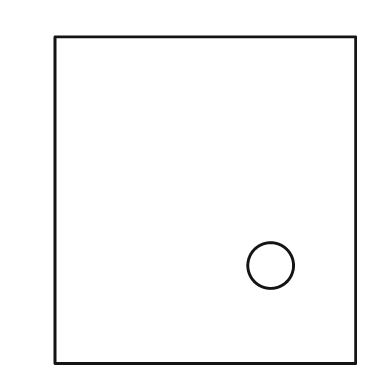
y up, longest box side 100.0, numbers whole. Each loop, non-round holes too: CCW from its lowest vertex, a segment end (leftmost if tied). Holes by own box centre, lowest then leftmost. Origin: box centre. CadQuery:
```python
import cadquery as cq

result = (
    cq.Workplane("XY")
    .moveTo(-46.0, -50.0)
    .lineTo(46.0, -50.0)
    .lineTo(46.0, 50.0)
    .lineTo(-46.0, 50.0)
    .close()
    .moveTo(20.0, -20.0)
    .circle(7.0)
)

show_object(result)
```